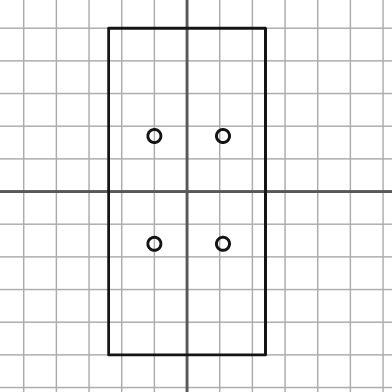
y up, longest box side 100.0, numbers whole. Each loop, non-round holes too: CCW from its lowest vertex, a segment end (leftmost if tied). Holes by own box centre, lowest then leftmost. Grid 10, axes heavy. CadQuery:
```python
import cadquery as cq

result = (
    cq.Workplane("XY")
    .moveTo(-24.0, -50.0)
    .lineTo(24.0, -50.0)
    .lineTo(24.0, 50.0)
    .lineTo(-24.0, 50.0)
    .close()
    .moveTo(-10.0, -16.0)
    .circle(2.0)
    .moveTo(11.0, -16.0)
    .circle(2.0)
    .moveTo(-10.0, 17.0)
    .circle(2.0)
    .moveTo(11.0, 17.0)
    .circle(2.0)
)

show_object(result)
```